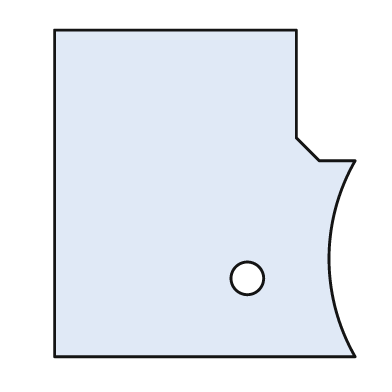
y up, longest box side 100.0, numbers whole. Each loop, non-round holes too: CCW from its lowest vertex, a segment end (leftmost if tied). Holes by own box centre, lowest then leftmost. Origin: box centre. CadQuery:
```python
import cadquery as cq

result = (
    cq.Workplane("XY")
    .moveTo(-46.0, -50.0)
    .lineTo(46.0, -50.0)
    .threePointArc((38.0, -20.0), (46.0, 10.0))
    .lineTo(35.0, 10.0)
    .lineTo(28.0, 17.0)
    .lineTo(28.0, 50.0)
    .lineTo(-46.0, 50.0)
    .close()
    .moveTo(13.0, -26.0)
    .circle(5.0)
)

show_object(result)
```